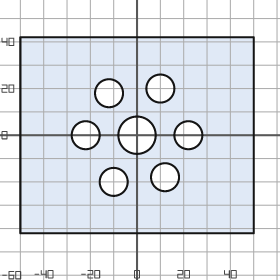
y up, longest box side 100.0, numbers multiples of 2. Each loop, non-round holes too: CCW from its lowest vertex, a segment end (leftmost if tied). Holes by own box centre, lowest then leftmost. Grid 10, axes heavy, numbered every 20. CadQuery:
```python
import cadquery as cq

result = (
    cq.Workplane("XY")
    .moveTo(-50.0, -42.0)
    .lineTo(50.0, -42.0)
    .lineTo(50.0, 42.0)
    .lineTo(-50.0, 42.0)
    .close()
    .moveTo(-10.0, -20.0)
    .circle(6.0)
    .moveTo(12.0, -18.0)
    .circle(6.0)
    .moveTo(-22.0, 0.0)
    .circle(6.0)
    .moveTo(0.0, 0.0)
    .circle(8.0)
    .moveTo(22.0, 0.0)
    .circle(6.0)
    .moveTo(-12.0, 18.0)
    .circle(6.0)
    .moveTo(10.0, 20.0)
    .circle(6.0)
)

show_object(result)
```